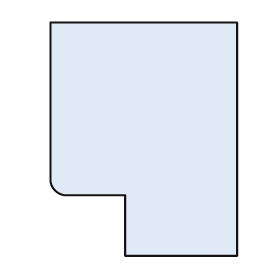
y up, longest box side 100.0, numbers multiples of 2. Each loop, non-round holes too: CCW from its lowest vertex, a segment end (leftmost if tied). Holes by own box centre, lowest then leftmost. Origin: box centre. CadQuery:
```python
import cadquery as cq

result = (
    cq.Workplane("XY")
    .moveTo(-8.0, -50.0)
    .lineTo(40.0, -50.0)
    .lineTo(40.0, 50.0)
    .lineTo(-40.0, 50.0)
    .lineTo(-40.0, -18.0)
    .threePointArc((-38.0, -22.0), (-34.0, -24.0))
    .lineTo(-8.0, -24.0)
    .close()
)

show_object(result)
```